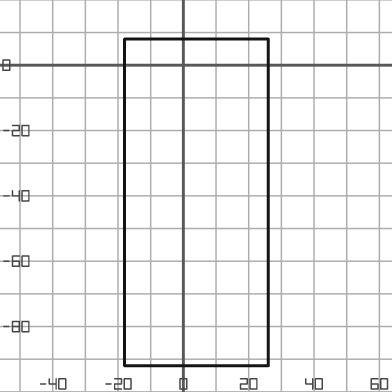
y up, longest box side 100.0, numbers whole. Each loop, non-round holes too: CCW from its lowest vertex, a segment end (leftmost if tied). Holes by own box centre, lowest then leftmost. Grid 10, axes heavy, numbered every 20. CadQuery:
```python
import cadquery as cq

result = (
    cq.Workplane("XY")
    .moveTo(-18.0, -92.0)
    .lineTo(26.0, -92.0)
    .lineTo(26.0, 8.0)
    .lineTo(-18.0, 8.0)
    .close()
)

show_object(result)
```